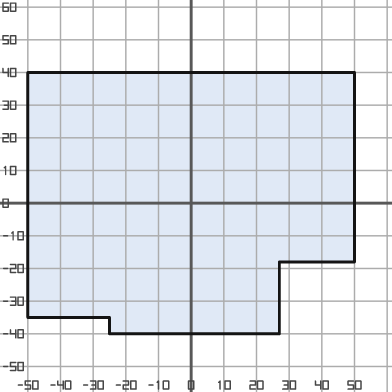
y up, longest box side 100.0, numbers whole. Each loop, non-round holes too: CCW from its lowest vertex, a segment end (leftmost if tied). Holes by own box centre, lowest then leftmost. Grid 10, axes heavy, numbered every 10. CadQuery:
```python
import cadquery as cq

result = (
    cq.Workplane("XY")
    .moveTo(-25.0, -40.0)
    .lineTo(27.0, -40.0)
    .lineTo(27.0, -18.0)
    .lineTo(50.0, -18.0)
    .lineTo(50.0, 40.0)
    .lineTo(-50.0, 40.0)
    .lineTo(-50.0, -35.0)
    .lineTo(-25.0, -35.0)
    .close()
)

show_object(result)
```